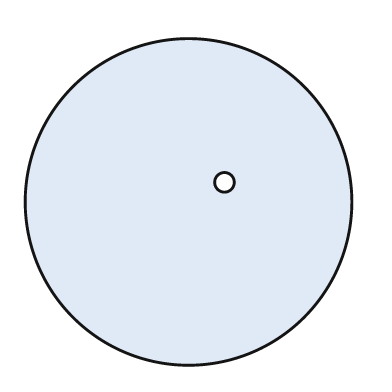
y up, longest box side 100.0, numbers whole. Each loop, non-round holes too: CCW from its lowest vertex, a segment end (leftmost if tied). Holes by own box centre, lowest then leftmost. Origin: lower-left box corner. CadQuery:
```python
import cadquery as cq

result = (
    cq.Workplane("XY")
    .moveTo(50.0, 50.0)
    .circle(50.0)
    .moveTo(61.0, 56.0)
    .circle(3.0)
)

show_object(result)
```